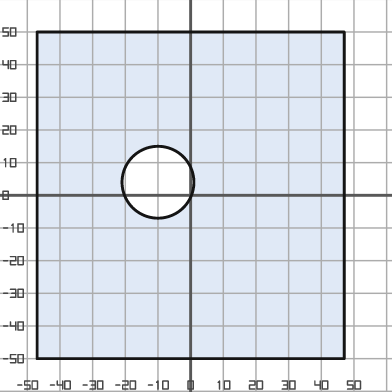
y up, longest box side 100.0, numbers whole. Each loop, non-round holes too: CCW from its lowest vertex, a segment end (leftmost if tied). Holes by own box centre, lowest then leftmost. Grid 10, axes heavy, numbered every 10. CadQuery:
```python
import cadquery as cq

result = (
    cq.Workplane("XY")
    .moveTo(-47.0, -50.0)
    .lineTo(47.0, -50.0)
    .lineTo(47.0, 50.0)
    .lineTo(-47.0, 50.0)
    .close()
    .moveTo(-10.0, 4.0)
    .circle(11.0)
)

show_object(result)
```